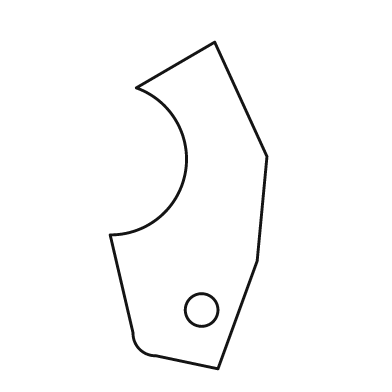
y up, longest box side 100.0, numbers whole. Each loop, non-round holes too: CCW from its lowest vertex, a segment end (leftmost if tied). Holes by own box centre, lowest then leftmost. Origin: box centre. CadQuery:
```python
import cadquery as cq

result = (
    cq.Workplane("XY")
    .moveTo(9.0, -50.0)
    .lineTo(21.0, -17.0)
    .lineTo(24.0, 15.0)
    .lineTo(8.0, 50.0)
    .lineTo(-16.0, 36.0)
    .threePointArc((-1.0, 10.0), (-24.0, -9.0))
    .lineTo(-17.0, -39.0)
    .threePointArc((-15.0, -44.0), (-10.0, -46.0))
    .close()
    .moveTo(4.0, -32.0)
    .circle(5.0)
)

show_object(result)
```